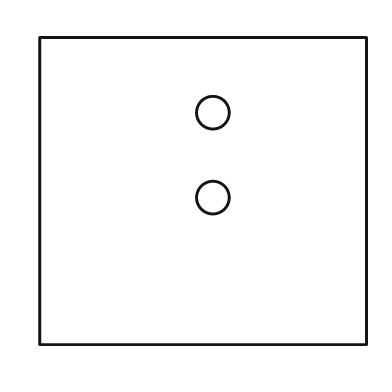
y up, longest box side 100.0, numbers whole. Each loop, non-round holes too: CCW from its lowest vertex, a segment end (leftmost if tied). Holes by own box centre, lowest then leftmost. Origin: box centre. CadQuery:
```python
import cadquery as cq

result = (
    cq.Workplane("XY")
    .moveTo(-50.0, -47.0)
    .lineTo(50.0, -47.0)
    .lineTo(50.0, 47.0)
    .lineTo(-50.0, 47.0)
    .close()
    .moveTo(3.0, -2.0)
    .circle(5.0)
    .moveTo(3.0, 24.0)
    .circle(5.0)
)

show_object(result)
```